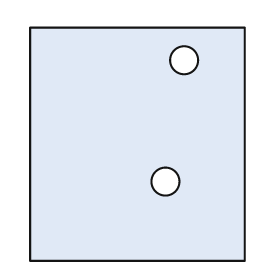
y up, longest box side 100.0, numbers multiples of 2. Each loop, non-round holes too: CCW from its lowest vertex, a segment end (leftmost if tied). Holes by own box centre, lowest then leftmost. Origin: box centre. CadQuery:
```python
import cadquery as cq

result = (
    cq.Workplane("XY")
    .moveTo(-46.0, -50.0)
    .lineTo(46.0, -50.0)
    .lineTo(46.0, 50.0)
    .lineTo(-46.0, 50.0)
    .close()
    .moveTo(12.0, -16.0)
    .circle(6.0)
    .moveTo(20.0, 36.0)
    .circle(6.0)
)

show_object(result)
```